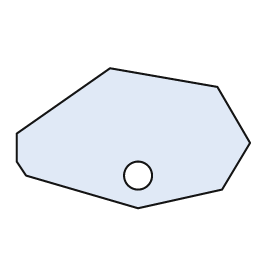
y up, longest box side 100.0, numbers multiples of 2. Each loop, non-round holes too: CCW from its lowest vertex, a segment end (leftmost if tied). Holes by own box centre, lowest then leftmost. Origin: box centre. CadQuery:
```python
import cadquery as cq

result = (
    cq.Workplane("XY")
    .moveTo(2.0, -30.0)
    .lineTo(38.0, -22.0)
    .lineTo(50.0, -2.0)
    .lineTo(36.0, 22.0)
    .lineTo(-10.0, 30.0)
    .lineTo(-50.0, 2.0)
    .lineTo(-50.0, -10.0)
    .lineTo(-46.0, -16.0)
    .close()
    .moveTo(2.0, -16.0)
    .circle(6.0)
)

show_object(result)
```